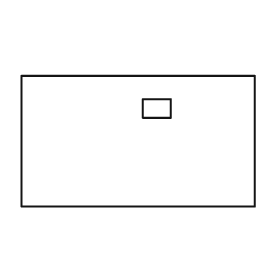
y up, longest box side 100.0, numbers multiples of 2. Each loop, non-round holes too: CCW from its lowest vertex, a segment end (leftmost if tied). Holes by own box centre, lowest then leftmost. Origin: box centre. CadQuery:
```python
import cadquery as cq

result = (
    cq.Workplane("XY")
    .moveTo(-50.0, -28.0)
    .lineTo(50.0, -28.0)
    .lineTo(50.0, 28.0)
    .lineTo(-50.0, 28.0)
    .close()
    .moveTo(2.0, 10.0)
    .lineTo(14.0, 10.0)
    .lineTo(14.0, 18.0)
    .lineTo(2.0, 18.0)
    .close()
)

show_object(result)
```